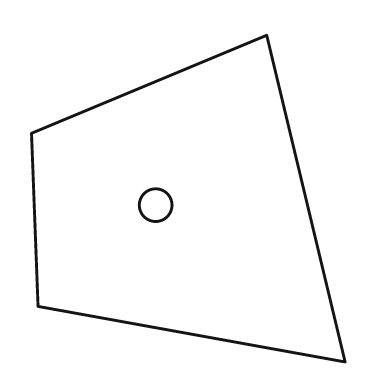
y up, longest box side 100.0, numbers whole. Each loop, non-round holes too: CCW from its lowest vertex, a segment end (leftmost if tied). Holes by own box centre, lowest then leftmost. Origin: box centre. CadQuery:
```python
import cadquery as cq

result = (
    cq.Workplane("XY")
    .moveTo(48.0, -50.0)
    .lineTo(24.0, 50.0)
    .lineTo(-48.0, 20.0)
    .lineTo(-46.0, -33.0)
    .close()
    .moveTo(-10.0, -2.0)
    .circle(5.0)
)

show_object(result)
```